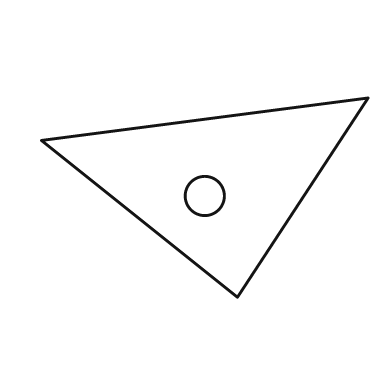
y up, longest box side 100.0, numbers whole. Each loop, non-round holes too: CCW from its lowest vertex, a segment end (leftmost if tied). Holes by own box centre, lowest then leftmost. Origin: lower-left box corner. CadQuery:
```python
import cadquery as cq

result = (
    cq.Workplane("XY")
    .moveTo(60.0, 0.0)
    .lineTo(100.0, 61.0)
    .lineTo(0.0, 48.0)
    .close()
    .moveTo(50.0, 31.0)
    .circle(6.0)
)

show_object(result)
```